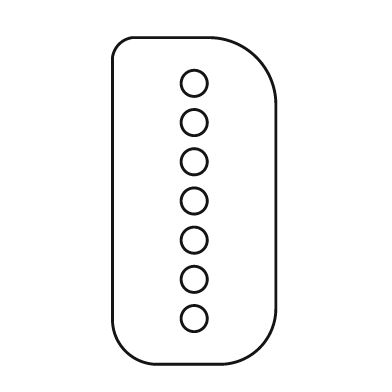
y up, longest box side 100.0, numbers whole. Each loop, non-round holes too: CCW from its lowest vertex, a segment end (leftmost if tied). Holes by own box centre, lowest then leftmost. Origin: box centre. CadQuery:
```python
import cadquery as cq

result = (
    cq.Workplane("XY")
    .moveTo(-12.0, -50.0)
    .lineTo(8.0, -50.0)
    .threePointArc((20.0, -45.0), (25.0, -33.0))
    .lineTo(25.0, 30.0)
    .threePointArc((19.0, 44.0), (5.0, 50.0))
    .lineTo(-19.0, 50.0)
    .threePointArc((-23.0, 48.0), (-25.0, 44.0))
    .lineTo(-25.0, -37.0)
    .threePointArc((-21.0, -46.0), (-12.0, -50.0))
    .close()
    .moveTo(0.0, -36.0)
    .circle(4.0)
    .moveTo(0.0, -24.0)
    .circle(4.0)
    .moveTo(0.0, -12.0)
    .circle(4.0)
    .moveTo(0.0, 0.0)
    .circle(4.0)
    .moveTo(0.0, 12.0)
    .circle(4.0)
    .moveTo(0.0, 24.0)
    .circle(4.0)
    .moveTo(0.0, 36.0)
    .circle(4.0)
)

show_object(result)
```